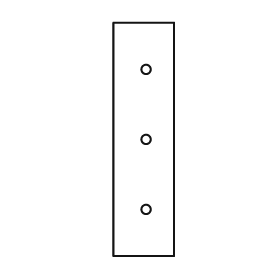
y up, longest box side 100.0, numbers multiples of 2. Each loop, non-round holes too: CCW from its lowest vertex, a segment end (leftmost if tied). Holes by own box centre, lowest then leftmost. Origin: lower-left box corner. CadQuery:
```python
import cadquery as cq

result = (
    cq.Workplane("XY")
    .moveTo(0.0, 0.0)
    .lineTo(26.0, 0.0)
    .lineTo(26.0, 100.0)
    .lineTo(0.0, 100.0)
    .close()
    .moveTo(14.0, 20.0)
    .circle(2.0)
    .moveTo(14.0, 50.0)
    .circle(2.0)
    .moveTo(14.0, 80.0)
    .circle(2.0)
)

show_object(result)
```